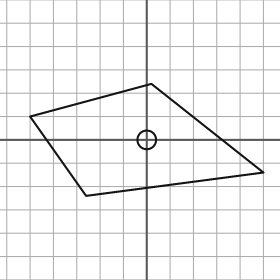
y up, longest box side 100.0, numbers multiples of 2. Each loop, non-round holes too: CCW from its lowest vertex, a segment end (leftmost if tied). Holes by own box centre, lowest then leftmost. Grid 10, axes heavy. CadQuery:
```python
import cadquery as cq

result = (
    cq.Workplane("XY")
    .moveTo(-26.0, -24.0)
    .lineTo(50.0, -14.0)
    .lineTo(2.0, 24.0)
    .lineTo(-50.0, 10.0)
    .close()
    .moveTo(0.0, 0.0)
    .circle(4.0)
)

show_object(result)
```